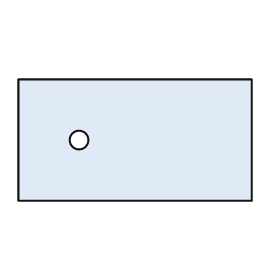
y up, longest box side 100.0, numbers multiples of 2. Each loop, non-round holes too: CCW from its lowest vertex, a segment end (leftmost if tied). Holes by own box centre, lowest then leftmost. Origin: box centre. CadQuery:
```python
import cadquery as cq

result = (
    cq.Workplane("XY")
    .moveTo(-50.0, -26.0)
    .lineTo(50.0, -26.0)
    .lineTo(50.0, 26.0)
    .lineTo(-50.0, 26.0)
    .close()
    .moveTo(-24.0, 0.0)
    .circle(4.0)
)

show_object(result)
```